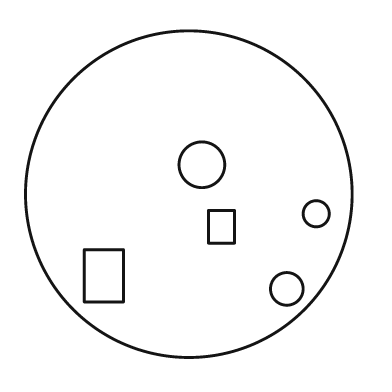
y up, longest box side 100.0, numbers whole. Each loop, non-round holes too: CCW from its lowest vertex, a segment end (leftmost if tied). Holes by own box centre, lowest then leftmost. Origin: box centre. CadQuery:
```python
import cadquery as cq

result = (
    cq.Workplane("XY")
    .moveTo(0.0, 0.0)
    .circle(50.0)
    .moveTo(30.0, -29.0)
    .circle(5.0)
    .moveTo(-32.0, -33.0)
    .lineTo(-20.0, -33.0)
    .lineTo(-20.0, -17.0)
    .lineTo(-32.0, -17.0)
    .close()
    .moveTo(6.0, -15.0)
    .lineTo(14.0, -15.0)
    .lineTo(14.0, -5.0)
    .lineTo(6.0, -5.0)
    .close()
    .moveTo(39.0, -6.0)
    .circle(4.0)
    .moveTo(4.0, 9.0)
    .circle(7.0)
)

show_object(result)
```